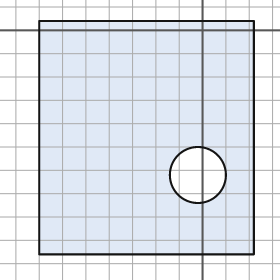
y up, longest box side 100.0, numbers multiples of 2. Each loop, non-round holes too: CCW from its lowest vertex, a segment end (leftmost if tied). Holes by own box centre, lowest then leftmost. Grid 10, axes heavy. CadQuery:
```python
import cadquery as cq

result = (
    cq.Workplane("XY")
    .moveTo(-70.0, -96.0)
    .lineTo(22.0, -96.0)
    .lineTo(22.0, 4.0)
    .lineTo(-70.0, 4.0)
    .close()
    .moveTo(-2.0, -62.0)
    .circle(12.0)
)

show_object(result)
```